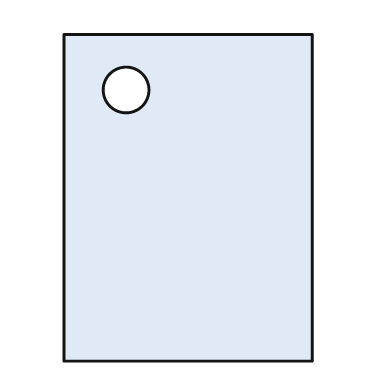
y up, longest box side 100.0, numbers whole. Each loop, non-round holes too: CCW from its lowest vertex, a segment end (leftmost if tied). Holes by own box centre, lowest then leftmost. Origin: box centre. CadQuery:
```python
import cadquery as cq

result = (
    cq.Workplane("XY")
    .moveTo(-38.0, -50.0)
    .lineTo(38.0, -50.0)
    .lineTo(38.0, 50.0)
    .lineTo(-38.0, 50.0)
    .close()
    .moveTo(-19.0, 33.0)
    .circle(7.0)
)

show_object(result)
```